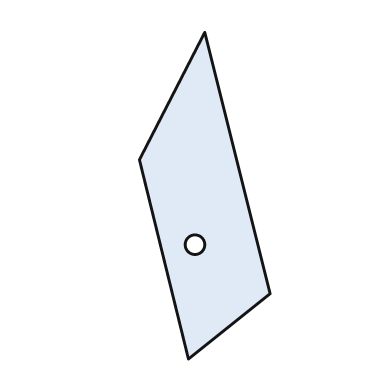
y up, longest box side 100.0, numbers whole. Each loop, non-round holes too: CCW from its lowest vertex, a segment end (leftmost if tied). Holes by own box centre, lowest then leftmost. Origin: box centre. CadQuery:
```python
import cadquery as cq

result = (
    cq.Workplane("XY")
    .moveTo(-5.0, -50.0)
    .lineTo(20.0, -30.0)
    .lineTo(0.0, 50.0)
    .lineTo(-20.0, 11.0)
    .close()
    .moveTo(-3.0, -15.0)
    .circle(3.0)
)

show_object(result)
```